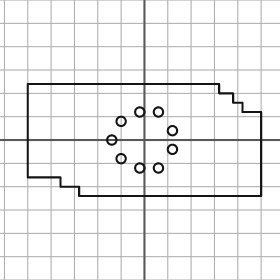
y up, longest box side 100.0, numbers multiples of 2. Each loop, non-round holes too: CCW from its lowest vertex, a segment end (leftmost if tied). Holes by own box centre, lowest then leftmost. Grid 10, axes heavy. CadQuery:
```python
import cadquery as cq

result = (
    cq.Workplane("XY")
    .moveTo(-28.0, -24.0)
    .lineTo(50.0, -24.0)
    .lineTo(50.0, 12.0)
    .lineTo(42.0, 12.0)
    .lineTo(42.0, 16.0)
    .lineTo(38.0, 16.0)
    .lineTo(38.0, 20.0)
    .lineTo(32.0, 20.0)
    .lineTo(32.0, 24.0)
    .lineTo(-50.0, 24.0)
    .lineTo(-50.0, -16.0)
    .lineTo(-36.0, -16.0)
    .lineTo(-36.0, -20.0)
    .lineTo(-28.0, -20.0)
    .close()
    .moveTo(-2.0, -12.0)
    .circle(2.0)
    .moveTo(6.0, -12.0)
    .circle(2.0)
    .moveTo(-10.0, -8.0)
    .circle(2.0)
    .moveTo(12.0, -4.0)
    .circle(2.0)
    .moveTo(-14.0, 0.0)
    .circle(2.0)
    .moveTo(12.0, 4.0)
    .circle(2.0)
    .moveTo(-10.0, 8.0)
    .circle(2.0)
    .moveTo(-2.0, 12.0)
    .circle(2.0)
    .moveTo(6.0, 12.0)
    .circle(2.0)
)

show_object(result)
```